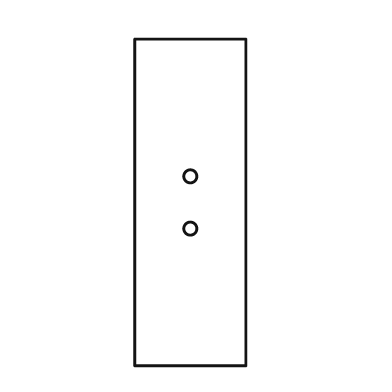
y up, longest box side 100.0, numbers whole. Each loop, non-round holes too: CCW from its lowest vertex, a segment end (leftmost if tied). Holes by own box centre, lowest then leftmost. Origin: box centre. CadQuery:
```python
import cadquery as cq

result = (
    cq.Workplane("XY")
    .moveTo(-17.0, -50.0)
    .lineTo(17.0, -50.0)
    .lineTo(17.0, 50.0)
    .lineTo(-17.0, 50.0)
    .close()
    .moveTo(0.0, -8.0)
    .circle(2.0)
    .moveTo(0.0, 8.0)
    .circle(2.0)
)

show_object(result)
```